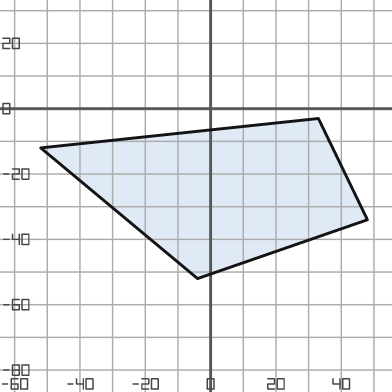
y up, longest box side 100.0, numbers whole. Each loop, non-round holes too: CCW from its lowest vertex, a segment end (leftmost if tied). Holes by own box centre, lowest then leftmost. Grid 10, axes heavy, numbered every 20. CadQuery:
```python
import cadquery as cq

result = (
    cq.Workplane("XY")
    .moveTo(-4.0, -52.0)
    .lineTo(48.0, -34.0)
    .lineTo(33.0, -3.0)
    .lineTo(-52.0, -12.0)
    .close()
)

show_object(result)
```